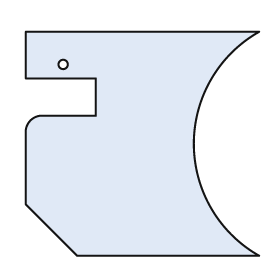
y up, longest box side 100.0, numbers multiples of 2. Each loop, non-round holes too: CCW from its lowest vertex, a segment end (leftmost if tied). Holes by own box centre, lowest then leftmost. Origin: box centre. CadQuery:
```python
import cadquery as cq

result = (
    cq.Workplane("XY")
    .moveTo(-28.0, -48.0)
    .lineTo(50.0, -48.0)
    .threePointArc((22.0, 0.0), (50.0, 48.0))
    .lineTo(-50.0, 48.0)
    .lineTo(-50.0, 28.0)
    .lineTo(-20.0, 28.0)
    .lineTo(-20.0, 12.0)
    .lineTo(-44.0, 12.0)
    .threePointArc((-48.0, 10.0), (-50.0, 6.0))
    .lineTo(-50.0, -26.0)
    .close()
    .moveTo(-34.0, 34.0)
    .circle(2.0)
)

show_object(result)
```